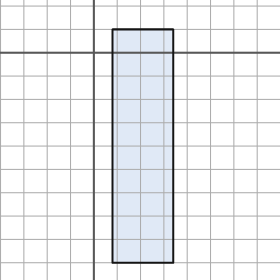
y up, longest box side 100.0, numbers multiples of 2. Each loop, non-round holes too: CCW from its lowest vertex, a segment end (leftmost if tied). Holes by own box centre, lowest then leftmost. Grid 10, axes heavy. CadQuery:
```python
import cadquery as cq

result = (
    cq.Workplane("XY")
    .moveTo(8.0, -90.0)
    .lineTo(34.0, -90.0)
    .lineTo(34.0, 10.0)
    .lineTo(8.0, 10.0)
    .close()
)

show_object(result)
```